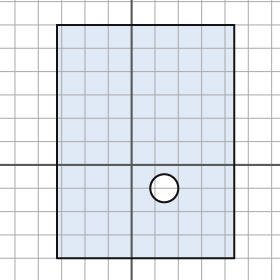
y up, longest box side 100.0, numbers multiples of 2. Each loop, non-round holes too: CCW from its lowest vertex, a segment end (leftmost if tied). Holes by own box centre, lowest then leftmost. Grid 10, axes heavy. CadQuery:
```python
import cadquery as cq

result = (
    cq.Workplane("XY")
    .moveTo(-32.0, -40.0)
    .lineTo(44.0, -40.0)
    .lineTo(44.0, 60.0)
    .lineTo(-32.0, 60.0)
    .close()
    .moveTo(14.0, -10.0)
    .circle(6.0)
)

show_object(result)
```